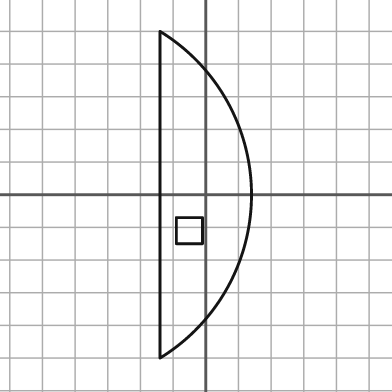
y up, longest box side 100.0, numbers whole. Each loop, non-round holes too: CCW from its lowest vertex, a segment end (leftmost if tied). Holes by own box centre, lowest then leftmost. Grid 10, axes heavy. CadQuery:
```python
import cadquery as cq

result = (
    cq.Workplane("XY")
    .moveTo(-14.0, -50.0)
    .threePointArc((14.0, 0.0), (-14.0, 50.0))
    .close()
    .moveTo(-9.0, -15.0)
    .lineTo(-1.0, -15.0)
    .lineTo(-1.0, -7.0)
    .lineTo(-9.0, -7.0)
    .close()
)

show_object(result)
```